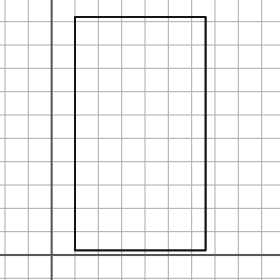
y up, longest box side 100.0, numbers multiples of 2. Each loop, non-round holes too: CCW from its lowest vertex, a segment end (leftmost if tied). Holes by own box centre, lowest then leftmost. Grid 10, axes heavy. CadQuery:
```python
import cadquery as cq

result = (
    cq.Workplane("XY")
    .moveTo(10.0, 2.0)
    .lineTo(66.0, 2.0)
    .lineTo(66.0, 102.0)
    .lineTo(10.0, 102.0)
    .close()
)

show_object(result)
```